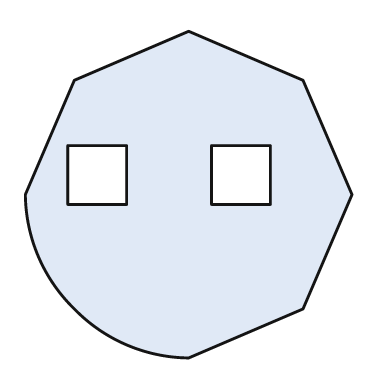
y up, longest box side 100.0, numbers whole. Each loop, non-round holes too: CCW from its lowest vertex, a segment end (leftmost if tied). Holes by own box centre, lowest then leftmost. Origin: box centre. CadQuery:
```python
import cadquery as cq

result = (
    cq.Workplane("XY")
    .moveTo(0.0, -50.0)
    .lineTo(35.0, -35.0)
    .lineTo(50.0, 0.0)
    .lineTo(35.0, 35.0)
    .lineTo(0.0, 50.0)
    .lineTo(-35.0, 35.0)
    .lineTo(-50.0, 0.0)
    .threePointArc((-46.0, -19.0), (-35.0, -35.0))
    .threePointArc((-19.0, -46.0), (0.0, -50.0))
    .close()
    .moveTo(-37.0, -3.0)
    .lineTo(-19.0, -3.0)
    .lineTo(-19.0, 15.0)
    .lineTo(-37.0, 15.0)
    .close()
    .moveTo(7.0, -3.0)
    .lineTo(25.0, -3.0)
    .lineTo(25.0, 15.0)
    .lineTo(7.0, 15.0)
    .close()
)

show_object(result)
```